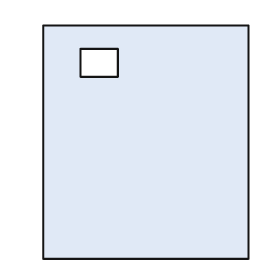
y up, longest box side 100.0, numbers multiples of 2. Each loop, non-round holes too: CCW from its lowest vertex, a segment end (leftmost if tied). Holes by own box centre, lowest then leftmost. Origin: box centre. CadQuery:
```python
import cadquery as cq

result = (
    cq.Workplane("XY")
    .moveTo(-44.0, -50.0)
    .lineTo(44.0, -50.0)
    .lineTo(44.0, 50.0)
    .lineTo(-44.0, 50.0)
    .close()
    .moveTo(-28.0, 28.0)
    .lineTo(-12.0, 28.0)
    .lineTo(-12.0, 40.0)
    .lineTo(-28.0, 40.0)
    .close()
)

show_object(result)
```